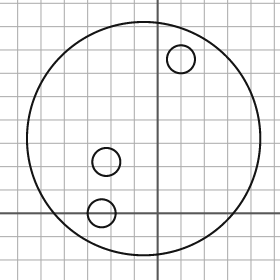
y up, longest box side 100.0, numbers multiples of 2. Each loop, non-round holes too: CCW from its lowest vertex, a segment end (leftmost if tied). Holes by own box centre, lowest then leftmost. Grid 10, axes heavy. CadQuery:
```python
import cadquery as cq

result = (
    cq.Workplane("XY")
    .moveTo(-6.0, 32.0)
    .circle(50.0)
    .moveTo(-24.0, 0.0)
    .circle(6.0)
    .moveTo(-22.0, 22.0)
    .circle(6.0)
    .moveTo(10.0, 66.0)
    .circle(6.0)
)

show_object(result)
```